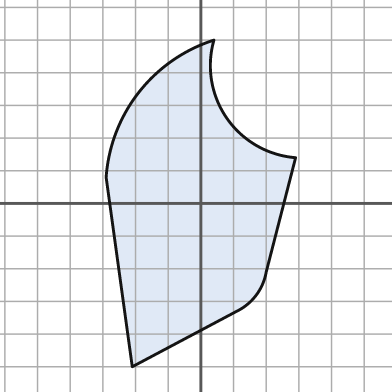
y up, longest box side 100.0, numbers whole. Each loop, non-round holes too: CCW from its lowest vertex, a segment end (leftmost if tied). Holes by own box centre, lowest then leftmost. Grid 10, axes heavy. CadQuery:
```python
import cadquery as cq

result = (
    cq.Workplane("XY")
    .moveTo(-21.0, -50.0)
    .lineTo(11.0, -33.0)
    .threePointArc((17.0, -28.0), (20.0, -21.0))
    .lineTo(29.0, 14.0)
    .threePointArc((8.0, 26.0), (4.0, 50.0))
    .threePointArc((-19.0, 34.0), (-29.0, 8.0))
    .close()
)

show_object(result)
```